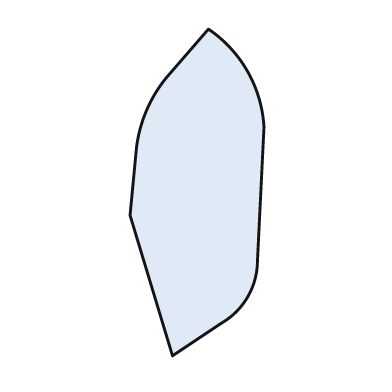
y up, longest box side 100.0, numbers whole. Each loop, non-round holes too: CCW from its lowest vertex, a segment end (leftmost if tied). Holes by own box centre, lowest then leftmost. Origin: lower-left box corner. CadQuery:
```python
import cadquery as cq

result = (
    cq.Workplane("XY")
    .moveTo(13.0, 0.0)
    .lineTo(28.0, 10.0)
    .threePointArc((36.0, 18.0), (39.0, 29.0))
    .lineTo(41.0, 70.0)
    .threePointArc((36.0, 87.0), (24.0, 100.0))
    .lineTo(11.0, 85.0)
    .threePointArc((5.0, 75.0), (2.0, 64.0))
    .lineTo(0.0, 43.0)
    .close()
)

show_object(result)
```